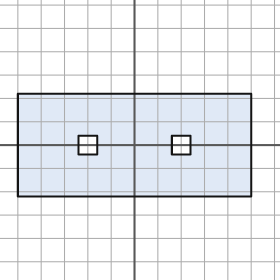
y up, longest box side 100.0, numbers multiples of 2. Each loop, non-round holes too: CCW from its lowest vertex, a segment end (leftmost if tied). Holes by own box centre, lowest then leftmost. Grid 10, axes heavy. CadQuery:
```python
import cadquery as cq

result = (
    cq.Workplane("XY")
    .moveTo(-50.0, -22.0)
    .lineTo(50.0, -22.0)
    .lineTo(50.0, 22.0)
    .lineTo(-50.0, 22.0)
    .close()
    .moveTo(-24.0, -4.0)
    .lineTo(-16.0, -4.0)
    .lineTo(-16.0, 4.0)
    .lineTo(-24.0, 4.0)
    .close()
    .moveTo(16.0, -4.0)
    .lineTo(24.0, -4.0)
    .lineTo(24.0, 4.0)
    .lineTo(16.0, 4.0)
    .close()
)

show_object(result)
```